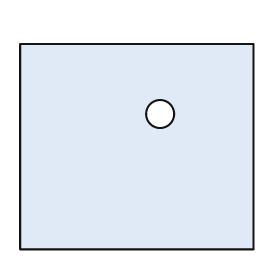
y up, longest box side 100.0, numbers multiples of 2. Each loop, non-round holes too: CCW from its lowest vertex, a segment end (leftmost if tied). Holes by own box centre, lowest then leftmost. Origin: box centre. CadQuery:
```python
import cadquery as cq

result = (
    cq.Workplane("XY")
    .moveTo(-50.0, -44.0)
    .lineTo(50.0, -44.0)
    .lineTo(50.0, 44.0)
    .lineTo(-50.0, 44.0)
    .close()
    .moveTo(10.0, 14.0)
    .circle(6.0)
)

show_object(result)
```